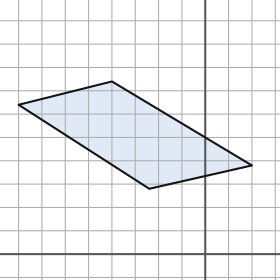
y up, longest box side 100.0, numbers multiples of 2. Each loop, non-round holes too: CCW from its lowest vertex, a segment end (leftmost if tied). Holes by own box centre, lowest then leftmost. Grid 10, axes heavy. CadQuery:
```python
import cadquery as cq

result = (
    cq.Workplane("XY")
    .moveTo(-24.0, 28.0)
    .lineTo(20.0, 38.0)
    .lineTo(-40.0, 74.0)
    .lineTo(-80.0, 64.0)
    .close()
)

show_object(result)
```